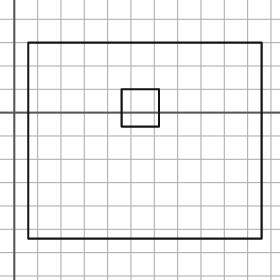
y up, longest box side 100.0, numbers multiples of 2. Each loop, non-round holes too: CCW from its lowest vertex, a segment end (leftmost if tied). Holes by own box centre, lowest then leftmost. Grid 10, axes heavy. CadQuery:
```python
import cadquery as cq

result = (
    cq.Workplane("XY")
    .moveTo(6.0, -54.0)
    .lineTo(106.0, -54.0)
    .lineTo(106.0, 30.0)
    .lineTo(6.0, 30.0)
    .close()
    .moveTo(46.0, -6.0)
    .lineTo(62.0, -6.0)
    .lineTo(62.0, 10.0)
    .lineTo(46.0, 10.0)
    .close()
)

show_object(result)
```